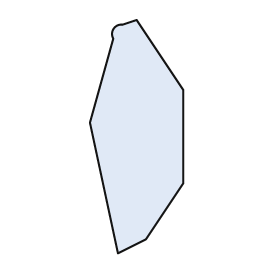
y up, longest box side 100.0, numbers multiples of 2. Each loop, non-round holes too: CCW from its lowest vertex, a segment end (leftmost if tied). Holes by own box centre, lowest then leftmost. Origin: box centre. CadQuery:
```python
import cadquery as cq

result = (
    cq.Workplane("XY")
    .moveTo(-8.0, -50.0)
    .lineTo(4.0, -44.0)
    .lineTo(20.0, -20.0)
    .lineTo(20.0, 20.0)
    .lineTo(0.0, 50.0)
    .lineTo(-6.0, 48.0)
    .threePointArc((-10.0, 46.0), (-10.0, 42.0))
    .lineTo(-20.0, 6.0)
    .close()
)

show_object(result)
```